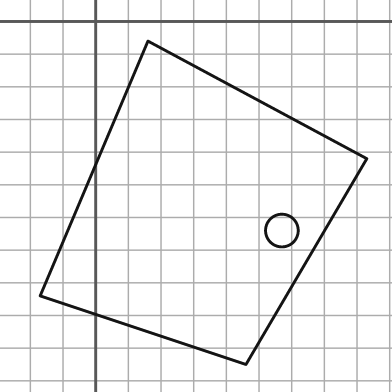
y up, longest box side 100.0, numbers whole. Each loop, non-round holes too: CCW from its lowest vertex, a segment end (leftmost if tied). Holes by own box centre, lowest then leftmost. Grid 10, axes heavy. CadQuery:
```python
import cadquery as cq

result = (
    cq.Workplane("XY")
    .moveTo(46.0, -105.0)
    .lineTo(83.0, -42.0)
    .lineTo(16.0, -6.0)
    .lineTo(-17.0, -84.0)
    .close()
    .moveTo(57.0, -64.0)
    .circle(5.0)
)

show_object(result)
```